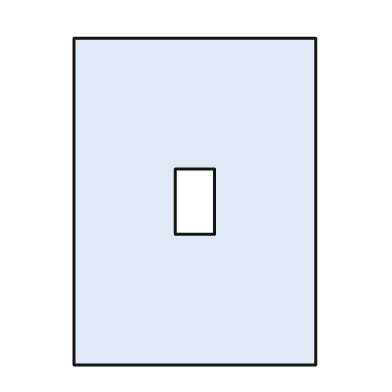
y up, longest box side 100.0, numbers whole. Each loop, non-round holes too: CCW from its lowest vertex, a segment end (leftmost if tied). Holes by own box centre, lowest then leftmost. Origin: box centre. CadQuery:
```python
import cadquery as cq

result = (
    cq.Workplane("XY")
    .moveTo(-37.0, -50.0)
    .lineTo(37.0, -50.0)
    .lineTo(37.0, 50.0)
    .lineTo(-37.0, 50.0)
    .close()
    .moveTo(-6.0, -10.0)
    .lineTo(6.0, -10.0)
    .lineTo(6.0, 10.0)
    .lineTo(-6.0, 10.0)
    .close()
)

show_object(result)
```